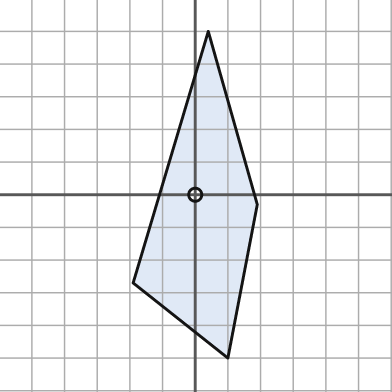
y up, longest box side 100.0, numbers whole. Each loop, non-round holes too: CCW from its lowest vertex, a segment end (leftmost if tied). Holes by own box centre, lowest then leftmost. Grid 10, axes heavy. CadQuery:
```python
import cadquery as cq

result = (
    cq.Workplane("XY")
    .moveTo(10.0, -50.0)
    .lineTo(19.0, -3.0)
    .lineTo(4.0, 50.0)
    .lineTo(-19.0, -27.0)
    .close()
    .moveTo(0.0, 0.0)
    .circle(2.0)
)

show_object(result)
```